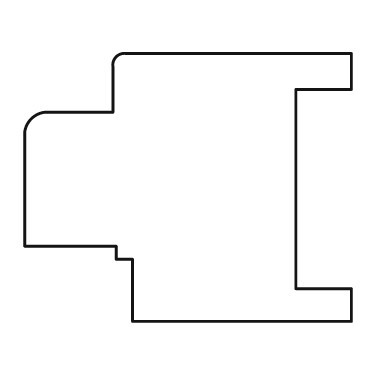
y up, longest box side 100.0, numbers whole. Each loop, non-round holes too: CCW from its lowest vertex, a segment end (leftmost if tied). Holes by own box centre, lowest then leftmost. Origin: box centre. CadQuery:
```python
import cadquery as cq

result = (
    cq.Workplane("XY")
    .moveTo(-17.0, -41.0)
    .lineTo(50.0, -41.0)
    .lineTo(50.0, -31.0)
    .lineTo(33.0, -31.0)
    .lineTo(33.0, 30.0)
    .lineTo(50.0, 30.0)
    .lineTo(50.0, 41.0)
    .lineTo(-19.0, 41.0)
    .threePointArc((-22.0, 40.0), (-23.0, 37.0))
    .lineTo(-23.0, 23.0)
    .lineTo(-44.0, 23.0)
    .threePointArc((-48.0, 21.0), (-50.0, 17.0))
    .lineTo(-50.0, -18.0)
    .lineTo(-22.0, -18.0)
    .lineTo(-22.0, -22.0)
    .lineTo(-17.0, -22.0)
    .close()
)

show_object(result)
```